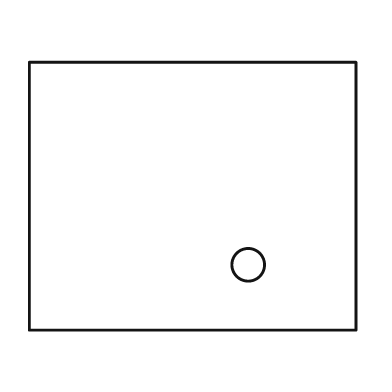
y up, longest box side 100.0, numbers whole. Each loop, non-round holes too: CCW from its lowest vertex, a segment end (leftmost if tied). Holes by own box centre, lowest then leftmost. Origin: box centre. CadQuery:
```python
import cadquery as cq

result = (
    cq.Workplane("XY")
    .moveTo(-50.0, -41.0)
    .lineTo(50.0, -41.0)
    .lineTo(50.0, 41.0)
    .lineTo(-50.0, 41.0)
    .close()
    .moveTo(17.0, -21.0)
    .circle(5.0)
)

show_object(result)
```